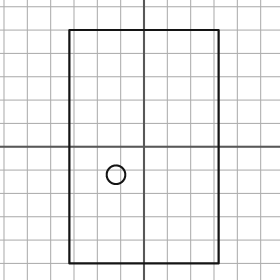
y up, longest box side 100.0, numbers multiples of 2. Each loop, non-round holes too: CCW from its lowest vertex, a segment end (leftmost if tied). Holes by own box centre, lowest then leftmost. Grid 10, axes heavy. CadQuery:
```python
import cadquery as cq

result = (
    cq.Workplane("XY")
    .moveTo(-32.0, -50.0)
    .lineTo(32.0, -50.0)
    .lineTo(32.0, 50.0)
    .lineTo(-32.0, 50.0)
    .close()
    .moveTo(-12.0, -12.0)
    .circle(4.0)
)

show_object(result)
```